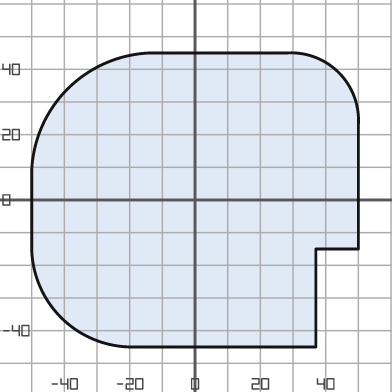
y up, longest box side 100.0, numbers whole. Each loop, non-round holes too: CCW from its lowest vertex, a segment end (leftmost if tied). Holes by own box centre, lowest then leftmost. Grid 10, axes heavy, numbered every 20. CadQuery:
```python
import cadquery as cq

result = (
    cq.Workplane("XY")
    .moveTo(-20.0, -45.0)
    .lineTo(37.0, -45.0)
    .lineTo(37.0, -15.0)
    .lineTo(50.0, -15.0)
    .lineTo(50.0, 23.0)
    .threePointArc((44.0, 39.0), (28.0, 45.0))
    .lineTo(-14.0, 45.0)
    .threePointArc((-39.0, 34.0), (-50.0, 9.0))
    .lineTo(-50.0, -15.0)
    .threePointArc((-41.0, -36.0), (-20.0, -45.0))
    .close()
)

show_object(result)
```